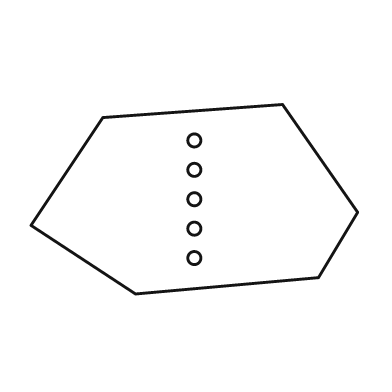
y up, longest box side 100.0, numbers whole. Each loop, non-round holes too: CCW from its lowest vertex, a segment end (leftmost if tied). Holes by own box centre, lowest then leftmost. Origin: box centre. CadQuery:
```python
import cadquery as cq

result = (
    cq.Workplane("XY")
    .moveTo(-18.0, -29.0)
    .lineTo(38.0, -24.0)
    .lineTo(50.0, -4.0)
    .lineTo(27.0, 29.0)
    .lineTo(-28.0, 25.0)
    .lineTo(-50.0, -8.0)
    .close()
    .moveTo(0.0, -18.0)
    .circle(2.0)
    .moveTo(0.0, -9.0)
    .circle(2.0)
    .moveTo(0.0, 0.0)
    .circle(2.0)
    .moveTo(0.0, 9.0)
    .circle(2.0)
    .moveTo(0.0, 18.0)
    .circle(2.0)
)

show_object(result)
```